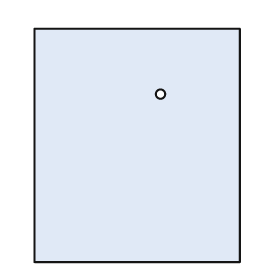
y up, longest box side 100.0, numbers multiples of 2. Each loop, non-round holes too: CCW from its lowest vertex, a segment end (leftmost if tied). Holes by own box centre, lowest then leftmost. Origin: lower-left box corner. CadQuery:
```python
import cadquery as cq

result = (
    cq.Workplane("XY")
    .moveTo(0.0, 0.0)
    .lineTo(88.0, 0.0)
    .lineTo(88.0, 100.0)
    .lineTo(0.0, 100.0)
    .close()
    .moveTo(54.0, 72.0)
    .circle(2.0)
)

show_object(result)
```